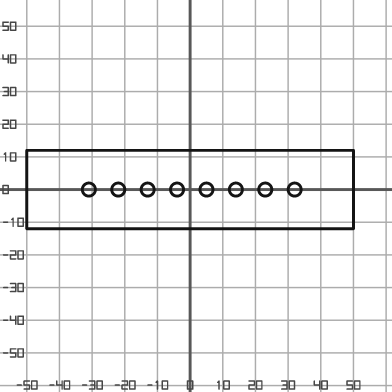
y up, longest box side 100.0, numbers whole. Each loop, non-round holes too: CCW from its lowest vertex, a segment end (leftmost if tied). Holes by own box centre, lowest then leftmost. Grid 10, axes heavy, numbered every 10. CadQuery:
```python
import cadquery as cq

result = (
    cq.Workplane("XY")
    .moveTo(-50.0, -12.0)
    .lineTo(50.0, -12.0)
    .lineTo(50.0, 12.0)
    .lineTo(-50.0, 12.0)
    .close()
    .moveTo(-31.0, 0.0)
    .circle(2.0)
    .moveTo(-22.0, 0.0)
    .circle(2.0)
    .moveTo(-13.0, 0.0)
    .circle(2.0)
    .moveTo(-4.0, 0.0)
    .circle(2.0)
    .moveTo(5.0, 0.0)
    .circle(2.0)
    .moveTo(14.0, 0.0)
    .circle(2.0)
    .moveTo(23.0, 0.0)
    .circle(2.0)
    .moveTo(32.0, 0.0)
    .circle(2.0)
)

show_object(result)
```